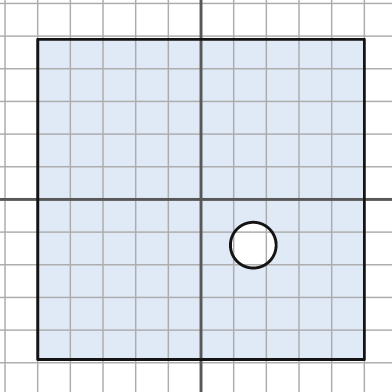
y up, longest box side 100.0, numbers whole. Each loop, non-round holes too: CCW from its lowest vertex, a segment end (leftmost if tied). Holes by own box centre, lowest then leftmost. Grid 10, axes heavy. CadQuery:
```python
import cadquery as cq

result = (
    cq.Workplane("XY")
    .moveTo(-50.0, -49.0)
    .lineTo(50.0, -49.0)
    .lineTo(50.0, 49.0)
    .lineTo(-50.0, 49.0)
    .close()
    .moveTo(16.0, -14.0)
    .circle(7.0)
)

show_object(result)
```